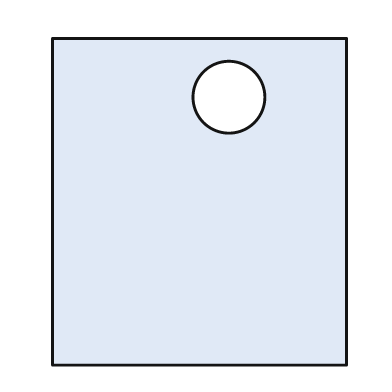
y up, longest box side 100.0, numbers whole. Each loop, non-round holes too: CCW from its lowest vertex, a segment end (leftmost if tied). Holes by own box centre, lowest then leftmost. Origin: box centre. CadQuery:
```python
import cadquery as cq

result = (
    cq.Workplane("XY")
    .moveTo(-45.0, -50.0)
    .lineTo(45.0, -50.0)
    .lineTo(45.0, 50.0)
    .lineTo(-45.0, 50.0)
    .close()
    .moveTo(9.0, 32.0)
    .circle(11.0)
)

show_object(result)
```